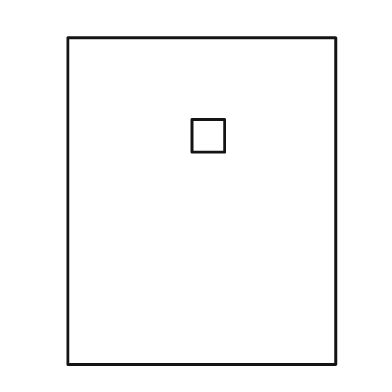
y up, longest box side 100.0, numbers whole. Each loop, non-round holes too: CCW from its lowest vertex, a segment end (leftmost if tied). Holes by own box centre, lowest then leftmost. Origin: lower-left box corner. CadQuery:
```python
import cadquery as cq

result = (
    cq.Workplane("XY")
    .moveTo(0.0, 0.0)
    .lineTo(82.0, 0.0)
    .lineTo(82.0, 100.0)
    .lineTo(0.0, 100.0)
    .close()
    .moveTo(38.0, 65.0)
    .lineTo(48.0, 65.0)
    .lineTo(48.0, 75.0)
    .lineTo(38.0, 75.0)
    .close()
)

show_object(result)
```